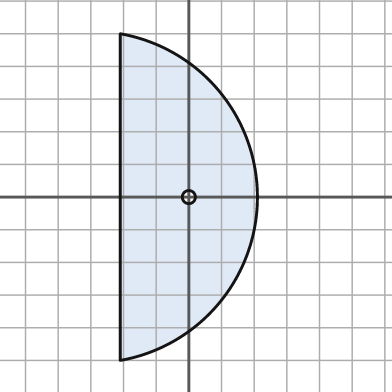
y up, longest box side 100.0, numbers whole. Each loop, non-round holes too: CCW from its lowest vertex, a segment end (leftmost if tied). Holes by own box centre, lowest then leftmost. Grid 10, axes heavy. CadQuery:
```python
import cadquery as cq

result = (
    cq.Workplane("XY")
    .moveTo(-21.0, -50.0)
    .threePointArc((21.0, 0.0), (-21.0, 50.0))
    .close()
    .moveTo(0.0, 0.0)
    .circle(2.0)
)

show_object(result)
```